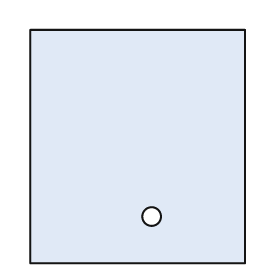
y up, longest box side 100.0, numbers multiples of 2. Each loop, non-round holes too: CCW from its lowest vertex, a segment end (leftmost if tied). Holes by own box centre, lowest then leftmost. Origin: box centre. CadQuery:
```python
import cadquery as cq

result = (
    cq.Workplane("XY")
    .moveTo(-46.0, -50.0)
    .lineTo(46.0, -50.0)
    .lineTo(46.0, 50.0)
    .lineTo(-46.0, 50.0)
    .close()
    .moveTo(6.0, -30.0)
    .circle(4.0)
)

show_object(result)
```